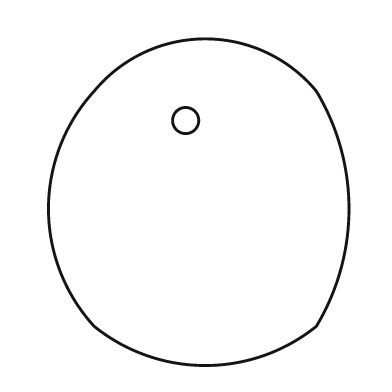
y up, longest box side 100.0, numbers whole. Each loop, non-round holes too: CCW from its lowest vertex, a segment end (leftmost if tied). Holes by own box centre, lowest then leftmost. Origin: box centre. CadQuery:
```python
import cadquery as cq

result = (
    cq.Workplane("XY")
    .moveTo(-32.0, -38.0)
    .threePointArc((2.0, -50.0), (36.0, -38.0))
    .threePointArc((46.0, -2.0), (36.0, 34.0))
    .threePointArc((2.0, 50.0), (-32.0, 34.0))
    .threePointArc((-46.0, -2.0), (-32.0, -38.0))
    .close()
    .moveTo(-4.0, 25.0)
    .circle(4.0)
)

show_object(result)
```